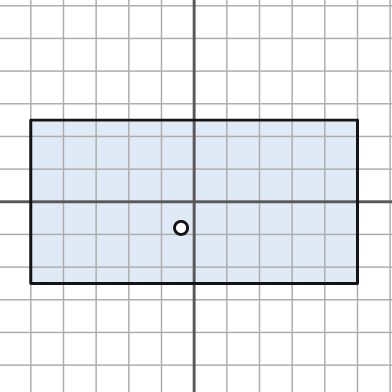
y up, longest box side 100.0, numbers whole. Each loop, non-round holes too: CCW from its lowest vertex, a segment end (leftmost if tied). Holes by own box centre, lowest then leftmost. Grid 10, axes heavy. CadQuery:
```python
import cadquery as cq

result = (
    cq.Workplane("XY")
    .moveTo(-50.0, -25.0)
    .lineTo(50.0, -25.0)
    .lineTo(50.0, 25.0)
    .lineTo(-50.0, 25.0)
    .close()
    .moveTo(-4.0, -8.0)
    .circle(2.0)
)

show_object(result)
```